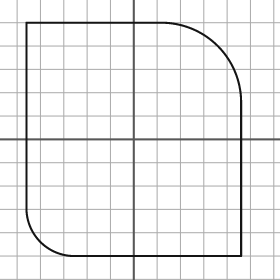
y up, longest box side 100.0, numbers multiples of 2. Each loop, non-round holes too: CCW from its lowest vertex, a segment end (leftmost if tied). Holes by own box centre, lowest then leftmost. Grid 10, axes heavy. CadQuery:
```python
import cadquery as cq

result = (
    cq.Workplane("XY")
    .moveTo(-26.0, -50.0)
    .lineTo(46.0, -50.0)
    .lineTo(46.0, 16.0)
    .threePointArc((36.0, 40.0), (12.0, 50.0))
    .lineTo(-46.0, 50.0)
    .lineTo(-46.0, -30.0)
    .threePointArc((-40.0, -44.0), (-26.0, -50.0))
    .close()
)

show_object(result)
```